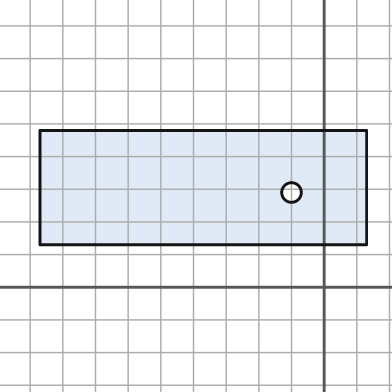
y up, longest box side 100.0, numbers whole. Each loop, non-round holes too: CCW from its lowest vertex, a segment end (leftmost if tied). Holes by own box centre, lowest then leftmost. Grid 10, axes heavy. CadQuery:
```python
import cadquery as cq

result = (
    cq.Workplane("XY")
    .moveTo(-87.0, 13.0)
    .lineTo(13.0, 13.0)
    .lineTo(13.0, 48.0)
    .lineTo(-87.0, 48.0)
    .close()
    .moveTo(-10.0, 29.0)
    .circle(3.0)
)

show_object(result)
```